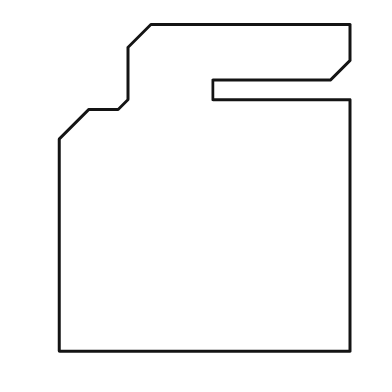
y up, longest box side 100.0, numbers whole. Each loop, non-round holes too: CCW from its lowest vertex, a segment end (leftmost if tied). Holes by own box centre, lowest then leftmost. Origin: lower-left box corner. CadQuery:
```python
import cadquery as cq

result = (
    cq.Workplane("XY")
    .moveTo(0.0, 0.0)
    .lineTo(89.0, 0.0)
    .lineTo(89.0, 77.0)
    .lineTo(47.0, 77.0)
    .lineTo(47.0, 83.0)
    .lineTo(83.0, 83.0)
    .lineTo(89.0, 89.0)
    .lineTo(89.0, 100.0)
    .lineTo(28.0, 100.0)
    .lineTo(21.0, 93.0)
    .lineTo(21.0, 77.0)
    .lineTo(18.0, 74.0)
    .lineTo(9.0, 74.0)
    .lineTo(0.0, 65.0)
    .close()
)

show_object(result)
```